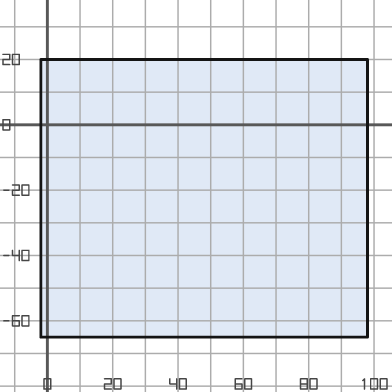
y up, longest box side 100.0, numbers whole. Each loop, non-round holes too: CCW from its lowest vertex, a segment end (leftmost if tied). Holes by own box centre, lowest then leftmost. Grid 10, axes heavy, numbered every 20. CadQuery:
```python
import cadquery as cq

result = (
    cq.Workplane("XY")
    .moveTo(-2.0, -65.0)
    .lineTo(98.0, -65.0)
    .lineTo(98.0, 20.0)
    .lineTo(-2.0, 20.0)
    .close()
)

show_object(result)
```